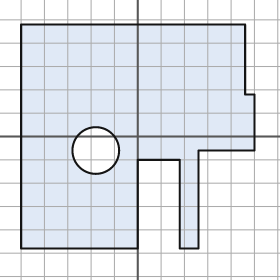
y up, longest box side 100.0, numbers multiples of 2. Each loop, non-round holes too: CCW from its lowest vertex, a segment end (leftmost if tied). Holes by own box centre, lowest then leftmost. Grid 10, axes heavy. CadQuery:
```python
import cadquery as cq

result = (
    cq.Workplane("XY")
    .moveTo(-50.0, -48.0)
    .lineTo(0.0, -48.0)
    .lineTo(0.0, -10.0)
    .lineTo(18.0, -10.0)
    .lineTo(18.0, -48.0)
    .lineTo(26.0, -48.0)
    .lineTo(26.0, -6.0)
    .lineTo(50.0, -6.0)
    .lineTo(50.0, 18.0)
    .lineTo(46.0, 18.0)
    .lineTo(46.0, 48.0)
    .lineTo(-50.0, 48.0)
    .close()
    .moveTo(-18.0, -6.0)
    .circle(10.0)
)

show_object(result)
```